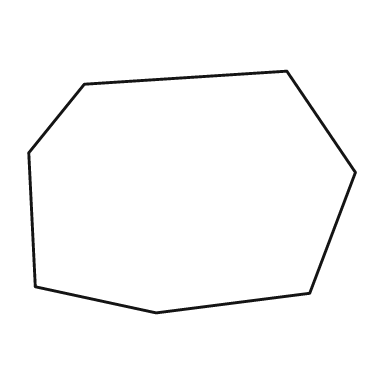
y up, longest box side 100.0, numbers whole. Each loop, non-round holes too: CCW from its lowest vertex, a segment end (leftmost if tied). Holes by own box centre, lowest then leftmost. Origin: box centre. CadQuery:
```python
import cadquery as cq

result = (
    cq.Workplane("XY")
    .moveTo(-11.0, -37.0)
    .lineTo(36.0, -31.0)
    .lineTo(50.0, 6.0)
    .lineTo(29.0, 37.0)
    .lineTo(-33.0, 33.0)
    .lineTo(-50.0, 12.0)
    .lineTo(-48.0, -29.0)
    .close()
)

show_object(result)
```